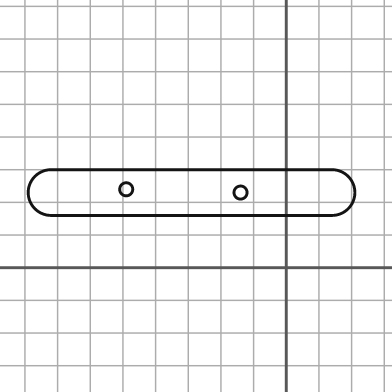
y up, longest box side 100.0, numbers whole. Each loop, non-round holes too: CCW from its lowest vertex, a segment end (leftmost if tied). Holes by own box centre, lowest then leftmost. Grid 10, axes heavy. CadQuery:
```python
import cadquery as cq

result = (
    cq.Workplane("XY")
    .moveTo(-72.0, 16.0)
    .lineTo(14.0, 16.0)
    .threePointArc((21.0, 23.0), (14.0, 30.0))
    .lineTo(-72.0, 30.0)
    .threePointArc((-79.0, 23.0), (-72.0, 16.0))
    .close()
    .moveTo(-14.0, 23.0)
    .circle(2.0)
    .moveTo(-49.0, 24.0)
    .circle(2.0)
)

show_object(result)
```